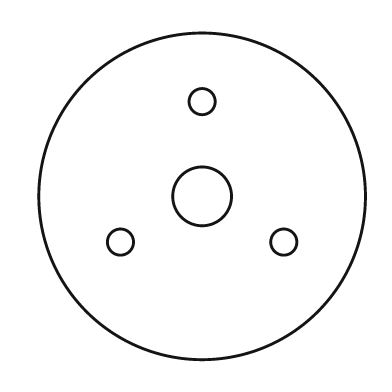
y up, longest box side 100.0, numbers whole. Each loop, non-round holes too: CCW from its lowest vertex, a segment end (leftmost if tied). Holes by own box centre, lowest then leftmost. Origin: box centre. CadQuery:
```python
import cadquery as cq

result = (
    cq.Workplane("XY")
    .moveTo(0.0, 0.0)
    .circle(50.0)
    .moveTo(-25.0, -14.0)
    .circle(4.0)
    .moveTo(25.0, -14.0)
    .circle(4.0)
    .moveTo(0.0, 0.0)
    .circle(9.0)
    .moveTo(0.0, 29.0)
    .circle(4.0)
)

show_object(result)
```